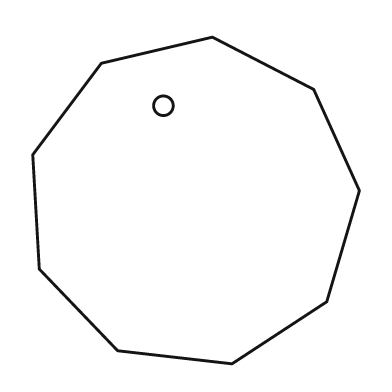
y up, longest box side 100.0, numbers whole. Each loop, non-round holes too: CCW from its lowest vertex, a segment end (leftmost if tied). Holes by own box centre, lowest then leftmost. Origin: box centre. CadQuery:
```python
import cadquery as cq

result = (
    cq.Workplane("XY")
    .moveTo(11.0, -50.0)
    .lineTo(40.0, -31.0)
    .lineTo(50.0, 3.0)
    .lineTo(36.0, 34.0)
    .lineTo(5.0, 50.0)
    .lineTo(-29.0, 42.0)
    .lineTo(-50.0, 14.0)
    .lineTo(-48.0, -21.0)
    .lineTo(-24.0, -46.0)
    .close()
    .moveTo(-10.0, 29.0)
    .circle(3.0)
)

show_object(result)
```